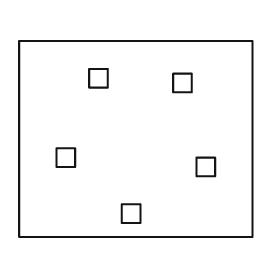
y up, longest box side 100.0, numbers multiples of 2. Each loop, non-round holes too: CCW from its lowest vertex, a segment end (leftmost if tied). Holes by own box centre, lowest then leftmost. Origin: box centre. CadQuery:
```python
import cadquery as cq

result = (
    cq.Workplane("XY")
    .moveTo(-50.0, -42.0)
    .lineTo(50.0, -42.0)
    .lineTo(50.0, 42.0)
    .lineTo(-50.0, 42.0)
    .close()
    .moveTo(-6.0, -36.0)
    .lineTo(2.0, -36.0)
    .lineTo(2.0, -28.0)
    .lineTo(-6.0, -28.0)
    .close()
    .moveTo(26.0, -16.0)
    .lineTo(34.0, -16.0)
    .lineTo(34.0, -8.0)
    .lineTo(26.0, -8.0)
    .close()
    .moveTo(-34.0, -12.0)
    .lineTo(-26.0, -12.0)
    .lineTo(-26.0, -4.0)
    .lineTo(-34.0, -4.0)
    .close()
    .moveTo(16.0, 20.0)
    .lineTo(24.0, 20.0)
    .lineTo(24.0, 28.0)
    .lineTo(16.0, 28.0)
    .close()
    .moveTo(-20.0, 22.0)
    .lineTo(-12.0, 22.0)
    .lineTo(-12.0, 30.0)
    .lineTo(-20.0, 30.0)
    .close()
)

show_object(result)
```